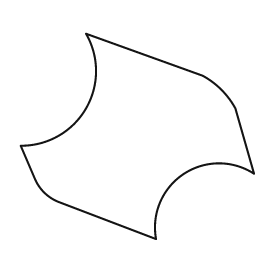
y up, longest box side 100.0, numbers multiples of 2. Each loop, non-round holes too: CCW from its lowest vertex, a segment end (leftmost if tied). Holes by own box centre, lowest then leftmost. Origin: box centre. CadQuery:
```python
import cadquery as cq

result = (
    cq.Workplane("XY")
    .moveTo(8.0, -44.0)
    .threePointArc((20.0, -16.0), (50.0, -16.0))
    .lineTo(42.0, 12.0)
    .threePointArc((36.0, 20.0), (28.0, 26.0))
    .lineTo(-22.0, 44.0)
    .threePointArc((-22.0, 12.0), (-50.0, -4.0))
    .lineTo(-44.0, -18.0)
    .threePointArc((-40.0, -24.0), (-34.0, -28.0))
    .close()
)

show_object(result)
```